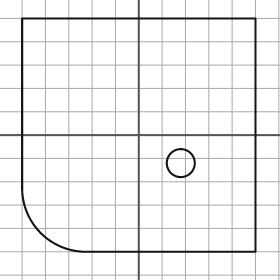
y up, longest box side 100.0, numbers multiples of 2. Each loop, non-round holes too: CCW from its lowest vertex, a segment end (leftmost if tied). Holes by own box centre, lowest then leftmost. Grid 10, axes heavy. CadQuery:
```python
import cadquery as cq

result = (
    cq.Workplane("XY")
    .moveTo(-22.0, -50.0)
    .lineTo(50.0, -50.0)
    .lineTo(50.0, 50.0)
    .lineTo(-50.0, 50.0)
    .lineTo(-50.0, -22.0)
    .threePointArc((-42.0, -42.0), (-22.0, -50.0))
    .close()
    .moveTo(18.0, -12.0)
    .circle(6.0)
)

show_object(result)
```